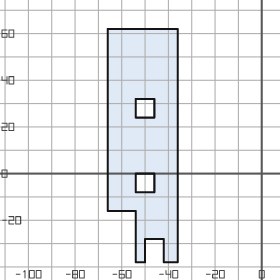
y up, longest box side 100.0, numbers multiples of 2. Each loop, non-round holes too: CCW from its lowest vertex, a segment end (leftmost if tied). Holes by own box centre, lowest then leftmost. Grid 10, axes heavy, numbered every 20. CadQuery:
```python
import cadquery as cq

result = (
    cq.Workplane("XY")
    .moveTo(-54.0, -38.0)
    .lineTo(-50.0, -38.0)
    .lineTo(-50.0, -28.0)
    .lineTo(-42.0, -28.0)
    .lineTo(-42.0, -38.0)
    .lineTo(-36.0, -38.0)
    .lineTo(-36.0, 62.0)
    .lineTo(-66.0, 62.0)
    .lineTo(-66.0, -16.0)
    .lineTo(-54.0, -16.0)
    .close()
    .moveTo(-54.0, -8.0)
    .lineTo(-46.0, -8.0)
    .lineTo(-46.0, 0.0)
    .lineTo(-54.0, 0.0)
    .close()
    .moveTo(-54.0, 24.0)
    .lineTo(-46.0, 24.0)
    .lineTo(-46.0, 32.0)
    .lineTo(-54.0, 32.0)
    .close()
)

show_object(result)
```